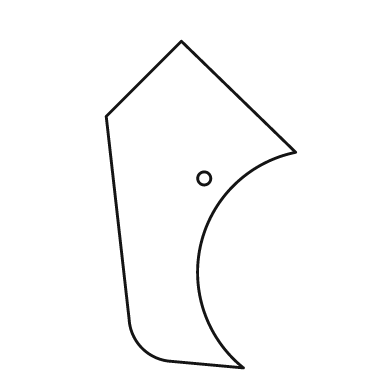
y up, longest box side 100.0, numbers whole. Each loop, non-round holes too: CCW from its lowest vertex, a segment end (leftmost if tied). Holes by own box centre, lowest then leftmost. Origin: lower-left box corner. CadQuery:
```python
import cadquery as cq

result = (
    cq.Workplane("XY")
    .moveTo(42.0, 0.0)
    .threePointArc((29.0, 38.0), (58.0, 66.0))
    .lineTo(23.0, 100.0)
    .lineTo(0.0, 77.0)
    .lineTo(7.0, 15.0)
    .threePointArc((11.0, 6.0), (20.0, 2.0))
    .close()
    .moveTo(30.0, 58.0)
    .circle(2.0)
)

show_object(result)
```